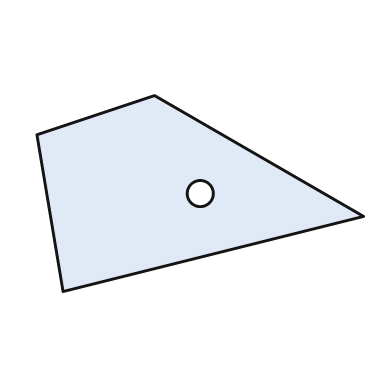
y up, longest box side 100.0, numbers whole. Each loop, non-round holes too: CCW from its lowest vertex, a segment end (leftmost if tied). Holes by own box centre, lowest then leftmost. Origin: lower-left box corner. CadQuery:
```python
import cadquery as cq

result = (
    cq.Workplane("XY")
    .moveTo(8.0, 0.0)
    .lineTo(100.0, 23.0)
    .lineTo(36.0, 60.0)
    .lineTo(0.0, 48.0)
    .close()
    .moveTo(50.0, 30.0)
    .circle(4.0)
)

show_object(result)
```